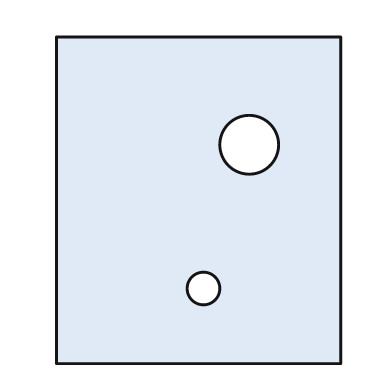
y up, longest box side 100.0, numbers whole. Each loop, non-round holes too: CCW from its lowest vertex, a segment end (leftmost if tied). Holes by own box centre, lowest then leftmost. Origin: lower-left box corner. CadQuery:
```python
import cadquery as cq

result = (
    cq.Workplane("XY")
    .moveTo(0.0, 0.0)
    .lineTo(87.0, 0.0)
    .lineTo(87.0, 100.0)
    .lineTo(0.0, 100.0)
    .close()
    .moveTo(45.0, 23.0)
    .circle(5.0)
    .moveTo(59.0, 67.0)
    .circle(9.0)
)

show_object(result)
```